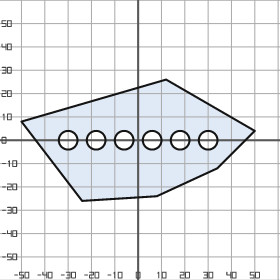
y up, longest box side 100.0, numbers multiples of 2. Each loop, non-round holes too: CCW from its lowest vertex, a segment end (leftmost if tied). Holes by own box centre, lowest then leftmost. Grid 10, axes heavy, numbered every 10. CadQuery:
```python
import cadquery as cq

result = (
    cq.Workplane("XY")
    .moveTo(-24.0, -26.0)
    .lineTo(8.0, -24.0)
    .lineTo(34.0, -12.0)
    .lineTo(50.0, 4.0)
    .lineTo(12.0, 26.0)
    .lineTo(-50.0, 8.0)
    .close()
    .moveTo(-30.0, 0.0)
    .circle(4.0)
    .moveTo(-18.0, 0.0)
    .circle(4.0)
    .moveTo(-6.0, 0.0)
    .circle(4.0)
    .moveTo(6.0, 0.0)
    .circle(4.0)
    .moveTo(18.0, 0.0)
    .circle(4.0)
    .moveTo(30.0, 0.0)
    .circle(4.0)
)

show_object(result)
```